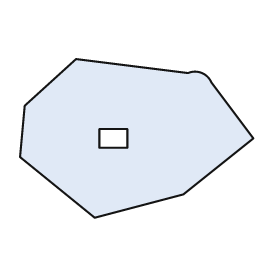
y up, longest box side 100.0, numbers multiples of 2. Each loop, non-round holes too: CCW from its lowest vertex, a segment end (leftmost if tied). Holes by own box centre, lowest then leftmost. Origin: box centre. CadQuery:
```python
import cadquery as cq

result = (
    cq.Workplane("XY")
    .moveTo(-18.0, -34.0)
    .lineTo(20.0, -24.0)
    .lineTo(50.0, 0.0)
    .lineTo(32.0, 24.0)
    .threePointArc((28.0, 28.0), (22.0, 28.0))
    .lineTo(-26.0, 34.0)
    .lineTo(-48.0, 14.0)
    .lineTo(-50.0, -8.0)
    .close()
    .moveTo(-16.0, -4.0)
    .lineTo(-4.0, -4.0)
    .lineTo(-4.0, 4.0)
    .lineTo(-16.0, 4.0)
    .close()
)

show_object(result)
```